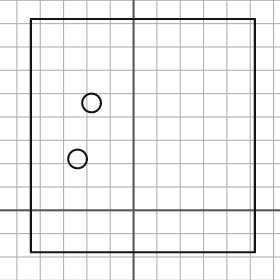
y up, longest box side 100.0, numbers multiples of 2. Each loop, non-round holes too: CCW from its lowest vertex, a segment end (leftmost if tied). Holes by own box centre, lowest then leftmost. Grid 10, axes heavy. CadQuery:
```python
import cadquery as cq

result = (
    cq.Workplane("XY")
    .moveTo(-44.0, -18.0)
    .lineTo(52.0, -18.0)
    .lineTo(52.0, 82.0)
    .lineTo(-44.0, 82.0)
    .close()
    .moveTo(-24.0, 22.0)
    .circle(4.0)
    .moveTo(-18.0, 46.0)
    .circle(4.0)
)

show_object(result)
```